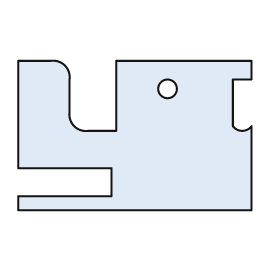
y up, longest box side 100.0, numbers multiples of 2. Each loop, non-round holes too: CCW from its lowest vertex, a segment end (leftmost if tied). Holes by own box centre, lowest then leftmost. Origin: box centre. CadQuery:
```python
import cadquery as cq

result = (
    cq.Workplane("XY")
    .moveTo(-50.0, -32.0)
    .lineTo(50.0, -32.0)
    .lineTo(50.0, 4.0)
    .threePointArc((46.0, 2.0), (42.0, 4.0))
    .lineTo(42.0, 24.0)
    .lineTo(50.0, 24.0)
    .lineTo(50.0, 32.0)
    .lineTo(-8.0, 32.0)
    .lineTo(-8.0, 2.0)
    .lineTo(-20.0, 2.0)
    .threePointArc((-26.0, 4.0), (-28.0, 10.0))
    .lineTo(-28.0, 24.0)
    .threePointArc((-30.0, 30.0), (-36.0, 32.0))
    .lineTo(-50.0, 32.0)
    .lineTo(-50.0, -14.0)
    .lineTo(-10.0, -14.0)
    .lineTo(-10.0, -26.0)
    .lineTo(-50.0, -26.0)
    .close()
    .moveTo(14.0, 20.0)
    .circle(4.0)
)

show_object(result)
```